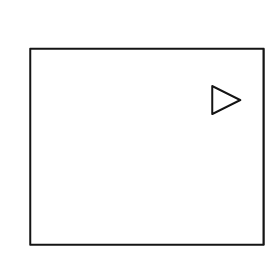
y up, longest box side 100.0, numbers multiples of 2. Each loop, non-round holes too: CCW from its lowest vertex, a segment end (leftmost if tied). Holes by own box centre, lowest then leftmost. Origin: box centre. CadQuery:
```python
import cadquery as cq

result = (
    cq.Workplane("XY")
    .moveTo(-50.0, -42.0)
    .lineTo(50.0, -42.0)
    .lineTo(50.0, 42.0)
    .lineTo(-50.0, 42.0)
    .close()
    .moveTo(28.0, 14.0)
    .lineTo(40.0, 20.0)
    .lineTo(28.0, 26.0)
    .close()
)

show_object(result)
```